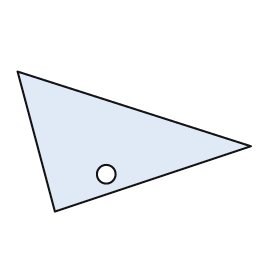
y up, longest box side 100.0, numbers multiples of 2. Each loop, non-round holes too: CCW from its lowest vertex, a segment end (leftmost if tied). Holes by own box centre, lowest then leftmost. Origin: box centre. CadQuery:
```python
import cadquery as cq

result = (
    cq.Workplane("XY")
    .moveTo(-34.0, -30.0)
    .lineTo(50.0, -2.0)
    .lineTo(-50.0, 30.0)
    .close()
    .moveTo(-12.0, -14.0)
    .circle(4.0)
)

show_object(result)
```